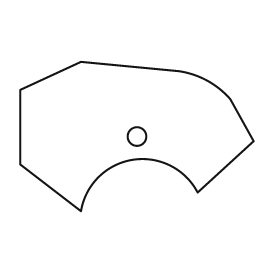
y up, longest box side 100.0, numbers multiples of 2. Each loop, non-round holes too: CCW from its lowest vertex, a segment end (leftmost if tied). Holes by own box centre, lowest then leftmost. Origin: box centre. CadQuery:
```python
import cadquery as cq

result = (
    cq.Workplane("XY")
    .moveTo(-24.0, -32.0)
    .threePointArc((-2.0, -10.0), (26.0, -24.0))
    .lineTo(50.0, -2.0)
    .lineTo(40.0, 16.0)
    .threePointArc((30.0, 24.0), (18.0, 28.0))
    .lineTo(-24.0, 32.0)
    .lineTo(-50.0, 20.0)
    .lineTo(-50.0, -12.0)
    .close()
    .moveTo(0.0, 0.0)
    .circle(4.0)
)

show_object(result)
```